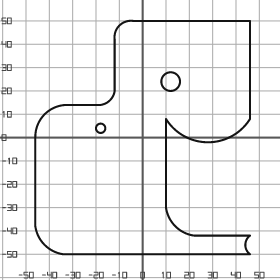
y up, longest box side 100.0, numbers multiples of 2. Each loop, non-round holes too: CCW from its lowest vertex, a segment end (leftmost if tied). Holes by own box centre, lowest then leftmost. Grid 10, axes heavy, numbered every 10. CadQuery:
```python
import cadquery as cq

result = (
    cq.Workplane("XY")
    .moveTo(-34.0, -50.0)
    .lineTo(46.0, -50.0)
    .threePointArc((44.0, -46.0), (46.0, -42.0))
    .lineTo(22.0, -42.0)
    .threePointArc((14.0, -38.0), (10.0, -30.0))
    .lineTo(10.0, 8.0)
    .threePointArc((28.0, -2.0), (46.0, 8.0))
    .lineTo(46.0, 50.0)
    .lineTo(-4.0, 50.0)
    .threePointArc((-10.0, 48.0), (-12.0, 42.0))
    .lineTo(-12.0, 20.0)
    .threePointArc((-14.0, 16.0), (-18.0, 14.0))
    .lineTo(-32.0, 14.0)
    .threePointArc((-42.0, 10.0), (-46.0, 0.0))
    .lineTo(-46.0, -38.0)
    .threePointArc((-42.0, -46.0), (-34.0, -50.0))
    .close()
    .moveTo(-18.0, 4.0)
    .circle(2.0)
    .moveTo(12.0, 24.0)
    .circle(4.0)
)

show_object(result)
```